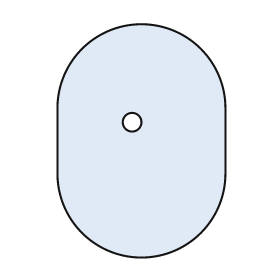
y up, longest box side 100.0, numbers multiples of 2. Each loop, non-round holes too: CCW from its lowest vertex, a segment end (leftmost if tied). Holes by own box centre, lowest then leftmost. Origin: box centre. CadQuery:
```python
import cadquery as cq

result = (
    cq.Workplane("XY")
    .moveTo(-36.0, -14.0)
    .threePointArc((0.0, -50.0), (36.0, -14.0))
    .lineTo(36.0, 14.0)
    .threePointArc((0.0, 50.0), (-36.0, 14.0))
    .close()
    .moveTo(-4.0, 8.0)
    .circle(4.0)
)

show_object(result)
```